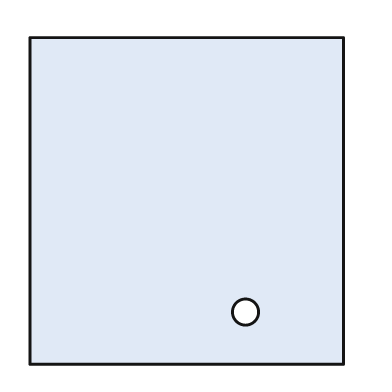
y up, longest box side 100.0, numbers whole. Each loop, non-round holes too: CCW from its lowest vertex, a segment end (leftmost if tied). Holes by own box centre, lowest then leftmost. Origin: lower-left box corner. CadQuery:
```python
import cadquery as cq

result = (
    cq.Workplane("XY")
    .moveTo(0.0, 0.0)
    .lineTo(96.0, 0.0)
    .lineTo(96.0, 100.0)
    .lineTo(0.0, 100.0)
    .close()
    .moveTo(66.0, 16.0)
    .circle(4.0)
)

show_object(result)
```